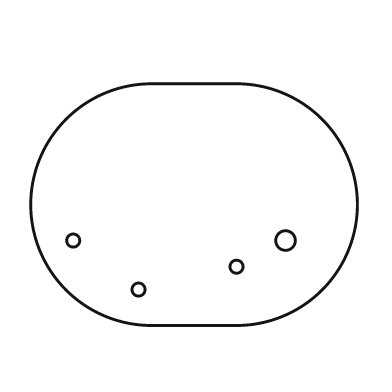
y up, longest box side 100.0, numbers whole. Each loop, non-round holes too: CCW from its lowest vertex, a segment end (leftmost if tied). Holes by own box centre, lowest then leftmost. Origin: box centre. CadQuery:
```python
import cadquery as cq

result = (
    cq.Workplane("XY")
    .moveTo(-13.0, -37.0)
    .lineTo(13.0, -37.0)
    .threePointArc((50.0, 0.0), (13.0, 37.0))
    .lineTo(-13.0, 37.0)
    .threePointArc((-50.0, 0.0), (-13.0, -37.0))
    .close()
    .moveTo(-17.0, -26.0)
    .circle(2.0)
    .moveTo(13.0, -19.0)
    .circle(2.0)
    .moveTo(-37.0, -11.0)
    .circle(2.0)
    .moveTo(28.0, -11.0)
    .circle(3.0)
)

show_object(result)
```